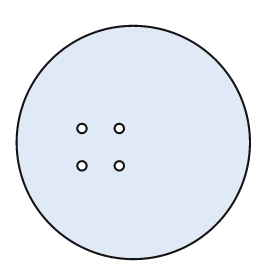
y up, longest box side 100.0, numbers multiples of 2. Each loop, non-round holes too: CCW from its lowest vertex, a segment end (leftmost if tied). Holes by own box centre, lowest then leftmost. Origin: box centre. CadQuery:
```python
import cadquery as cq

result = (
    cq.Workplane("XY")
    .moveTo(0.0, 0.0)
    .circle(50.0)
    .moveTo(-22.0, -10.0)
    .circle(2.0)
    .moveTo(-6.0, -10.0)
    .circle(2.0)
    .moveTo(-22.0, 6.0)
    .circle(2.0)
    .moveTo(-6.0, 6.0)
    .circle(2.0)
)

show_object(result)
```